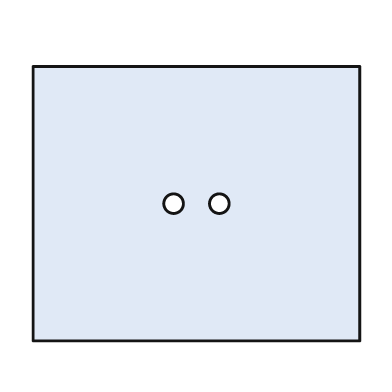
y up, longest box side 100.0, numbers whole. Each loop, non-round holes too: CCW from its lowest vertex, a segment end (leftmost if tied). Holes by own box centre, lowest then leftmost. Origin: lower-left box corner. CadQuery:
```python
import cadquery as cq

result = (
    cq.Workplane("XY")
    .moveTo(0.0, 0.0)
    .lineTo(100.0, 0.0)
    .lineTo(100.0, 84.0)
    .lineTo(0.0, 84.0)
    .close()
    .moveTo(43.0, 42.0)
    .circle(3.0)
    .moveTo(57.0, 42.0)
    .circle(3.0)
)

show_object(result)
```